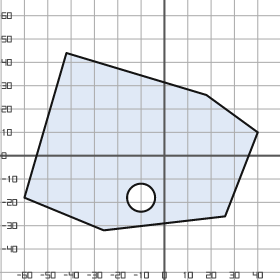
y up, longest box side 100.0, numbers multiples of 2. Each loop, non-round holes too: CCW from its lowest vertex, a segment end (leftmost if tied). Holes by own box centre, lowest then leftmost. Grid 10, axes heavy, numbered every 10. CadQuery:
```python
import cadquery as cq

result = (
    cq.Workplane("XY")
    .moveTo(-26.0, -32.0)
    .lineTo(26.0, -26.0)
    .lineTo(40.0, 10.0)
    .lineTo(18.0, 26.0)
    .lineTo(-42.0, 44.0)
    .lineTo(-60.0, -18.0)
    .close()
    .moveTo(-10.0, -18.0)
    .circle(6.0)
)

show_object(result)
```